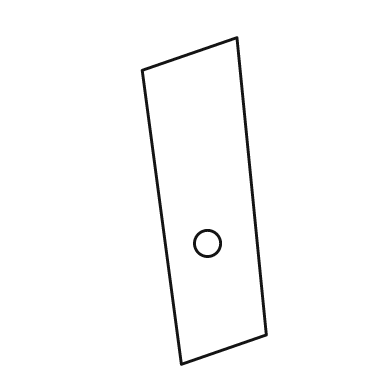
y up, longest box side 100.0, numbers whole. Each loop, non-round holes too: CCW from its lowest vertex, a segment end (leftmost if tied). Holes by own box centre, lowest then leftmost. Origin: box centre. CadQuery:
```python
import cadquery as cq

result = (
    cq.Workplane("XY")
    .moveTo(-7.0, -50.0)
    .lineTo(19.0, -41.0)
    .lineTo(10.0, 50.0)
    .lineTo(-19.0, 40.0)
    .close()
    .moveTo(1.0, -13.0)
    .circle(4.0)
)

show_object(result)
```